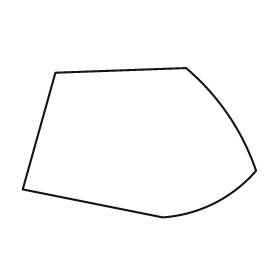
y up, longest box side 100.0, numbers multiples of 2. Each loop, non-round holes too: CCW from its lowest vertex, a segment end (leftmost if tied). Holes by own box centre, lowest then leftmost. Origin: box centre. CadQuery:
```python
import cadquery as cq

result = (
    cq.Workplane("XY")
    .moveTo(10.0, -32.0)
    .threePointArc((32.0, -26.0), (50.0, -12.0))
    .threePointArc((38.0, 12.0), (20.0, 32.0))
    .lineTo(-36.0, 30.0)
    .lineTo(-50.0, -20.0)
    .close()
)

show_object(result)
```